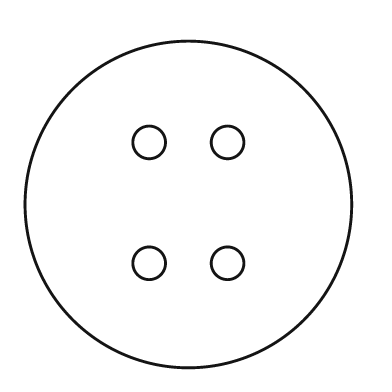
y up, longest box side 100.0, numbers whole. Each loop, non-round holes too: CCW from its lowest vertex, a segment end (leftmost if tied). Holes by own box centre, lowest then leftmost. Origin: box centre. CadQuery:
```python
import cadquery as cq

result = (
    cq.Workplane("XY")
    .moveTo(0.0, 0.0)
    .circle(50.0)
    .moveTo(-12.0, -18.0)
    .circle(5.0)
    .moveTo(12.0, -18.0)
    .circle(5.0)
    .moveTo(-12.0, 19.0)
    .circle(5.0)
    .moveTo(12.0, 19.0)
    .circle(5.0)
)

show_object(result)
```